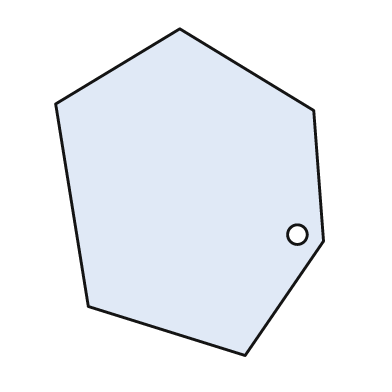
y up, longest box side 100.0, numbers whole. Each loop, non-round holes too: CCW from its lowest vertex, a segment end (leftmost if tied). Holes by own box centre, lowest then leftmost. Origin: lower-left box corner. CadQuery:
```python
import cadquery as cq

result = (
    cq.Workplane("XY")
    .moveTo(58.0, 0.0)
    .lineTo(82.0, 35.0)
    .lineTo(79.0, 75.0)
    .lineTo(38.0, 100.0)
    .lineTo(0.0, 77.0)
    .lineTo(10.0, 15.0)
    .close()
    .moveTo(74.0, 37.0)
    .circle(3.0)
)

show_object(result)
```